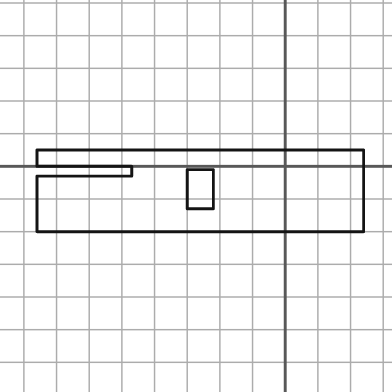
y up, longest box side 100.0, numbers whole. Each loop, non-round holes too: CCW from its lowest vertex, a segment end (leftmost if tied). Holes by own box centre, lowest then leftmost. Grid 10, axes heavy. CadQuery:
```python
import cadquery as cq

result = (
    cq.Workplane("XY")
    .moveTo(-76.0, -20.0)
    .lineTo(24.0, -20.0)
    .lineTo(24.0, 5.0)
    .lineTo(-76.0, 5.0)
    .lineTo(-76.0, 0.0)
    .lineTo(-47.0, 0.0)
    .lineTo(-47.0, -3.0)
    .lineTo(-76.0, -3.0)
    .close()
    .moveTo(-30.0, -13.0)
    .lineTo(-22.0, -13.0)
    .lineTo(-22.0, -1.0)
    .lineTo(-30.0, -1.0)
    .close()
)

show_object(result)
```